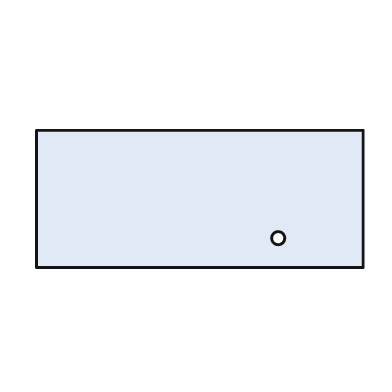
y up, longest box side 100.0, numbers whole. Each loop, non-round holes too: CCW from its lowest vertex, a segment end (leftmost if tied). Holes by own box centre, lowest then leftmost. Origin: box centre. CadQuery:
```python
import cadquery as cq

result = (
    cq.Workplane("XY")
    .moveTo(-50.0, -21.0)
    .lineTo(50.0, -21.0)
    .lineTo(50.0, 21.0)
    .lineTo(-50.0, 21.0)
    .close()
    .moveTo(24.0, -12.0)
    .circle(2.0)
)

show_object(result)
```